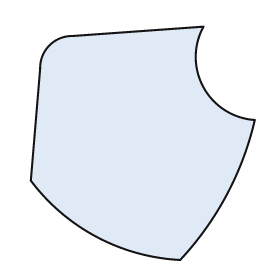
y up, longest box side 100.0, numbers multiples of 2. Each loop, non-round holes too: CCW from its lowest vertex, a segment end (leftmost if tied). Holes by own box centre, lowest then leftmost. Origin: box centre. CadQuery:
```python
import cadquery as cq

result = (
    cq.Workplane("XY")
    .moveTo(16.0, -50.0)
    .threePointArc((36.0, -22.0), (48.0, 10.0))
    .threePointArc((26.0, 24.0), (26.0, 50.0))
    .lineTo(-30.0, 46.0)
    .threePointArc((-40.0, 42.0), (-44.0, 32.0))
    .lineTo(-48.0, -16.0)
    .threePointArc((-20.0, -40.0), (16.0, -50.0))
    .close()
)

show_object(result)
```